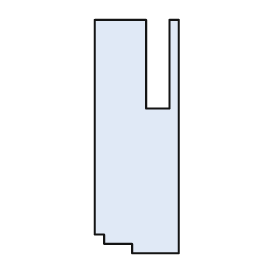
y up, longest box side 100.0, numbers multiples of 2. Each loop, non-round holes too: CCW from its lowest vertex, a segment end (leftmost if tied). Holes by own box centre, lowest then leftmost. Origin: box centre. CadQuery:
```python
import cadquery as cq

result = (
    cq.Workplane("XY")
    .moveTo(-2.0, -50.0)
    .lineTo(18.0, -50.0)
    .lineTo(18.0, 50.0)
    .lineTo(14.0, 50.0)
    .lineTo(14.0, 12.0)
    .lineTo(4.0, 12.0)
    .lineTo(4.0, 50.0)
    .lineTo(-18.0, 50.0)
    .lineTo(-18.0, -42.0)
    .lineTo(-14.0, -42.0)
    .lineTo(-14.0, -46.0)
    .lineTo(-2.0, -46.0)
    .close()
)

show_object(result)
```